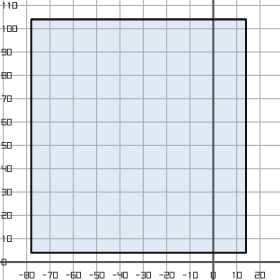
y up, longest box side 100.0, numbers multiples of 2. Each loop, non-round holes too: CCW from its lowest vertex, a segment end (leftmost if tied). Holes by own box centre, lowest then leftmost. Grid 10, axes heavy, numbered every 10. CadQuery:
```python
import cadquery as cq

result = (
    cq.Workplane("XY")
    .moveTo(-78.0, 4.0)
    .lineTo(14.0, 4.0)
    .lineTo(14.0, 104.0)
    .lineTo(-78.0, 104.0)
    .close()
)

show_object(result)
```